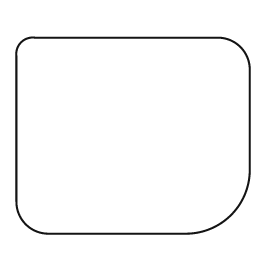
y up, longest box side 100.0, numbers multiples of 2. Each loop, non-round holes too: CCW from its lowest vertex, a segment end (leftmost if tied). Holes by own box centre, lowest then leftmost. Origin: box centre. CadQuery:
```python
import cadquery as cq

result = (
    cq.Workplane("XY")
    .moveTo(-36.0, -42.0)
    .lineTo(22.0, -42.0)
    .threePointArc((42.0, -34.0), (50.0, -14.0))
    .lineTo(50.0, 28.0)
    .threePointArc((46.0, 38.0), (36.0, 42.0))
    .lineTo(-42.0, 42.0)
    .threePointArc((-48.0, 40.0), (-50.0, 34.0))
    .lineTo(-50.0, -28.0)
    .threePointArc((-46.0, -38.0), (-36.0, -42.0))
    .close()
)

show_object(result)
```